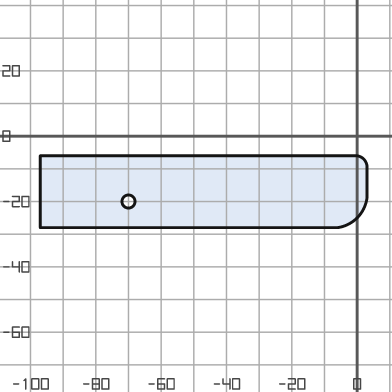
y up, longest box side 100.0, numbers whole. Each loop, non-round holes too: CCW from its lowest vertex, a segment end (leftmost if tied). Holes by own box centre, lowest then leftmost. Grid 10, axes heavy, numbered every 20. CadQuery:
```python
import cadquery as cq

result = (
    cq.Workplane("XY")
    .moveTo(-97.0, -28.0)
    .lineTo(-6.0, -28.0)
    .threePointArc((0.0, -25.0), (3.0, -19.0))
    .lineTo(3.0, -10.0)
    .threePointArc((2.0, -7.0), (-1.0, -6.0))
    .lineTo(-97.0, -6.0)
    .close()
    .moveTo(-70.0, -20.0)
    .circle(2.0)
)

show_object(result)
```